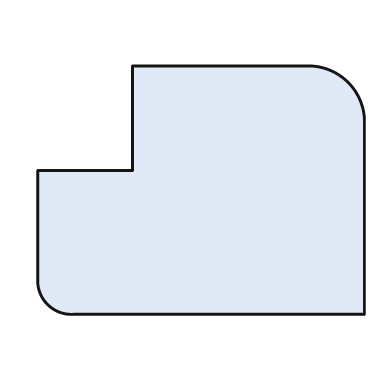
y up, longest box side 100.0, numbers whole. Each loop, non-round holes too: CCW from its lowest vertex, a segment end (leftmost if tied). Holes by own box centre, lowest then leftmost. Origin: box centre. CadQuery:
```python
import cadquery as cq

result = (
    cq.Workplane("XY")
    .moveTo(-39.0, -38.0)
    .lineTo(50.0, -38.0)
    .lineTo(50.0, 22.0)
    .threePointArc((45.0, 33.0), (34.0, 38.0))
    .lineTo(-21.0, 38.0)
    .lineTo(-21.0, 6.0)
    .lineTo(-50.0, 6.0)
    .lineTo(-50.0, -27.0)
    .threePointArc((-47.0, -35.0), (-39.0, -38.0))
    .close()
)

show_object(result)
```